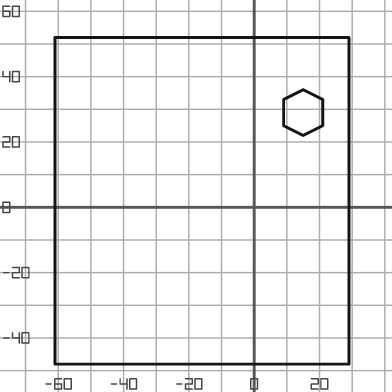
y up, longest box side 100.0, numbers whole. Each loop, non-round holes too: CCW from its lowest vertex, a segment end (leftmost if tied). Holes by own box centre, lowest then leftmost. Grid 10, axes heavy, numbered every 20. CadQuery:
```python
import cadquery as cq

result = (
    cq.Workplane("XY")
    .moveTo(-61.0, -48.0)
    .lineTo(29.0, -48.0)
    .lineTo(29.0, 52.0)
    .lineTo(-61.0, 52.0)
    .close()
    .moveTo(15.0, 22.0)
    .lineTo(21.0, 25.0)
    .lineTo(21.0, 33.0)
    .lineTo(15.0, 36.0)
    .lineTo(9.0, 33.0)
    .lineTo(9.0, 25.0)
    .close()
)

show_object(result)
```